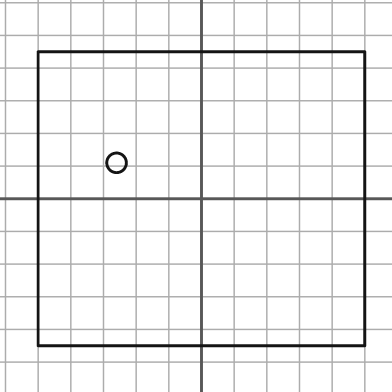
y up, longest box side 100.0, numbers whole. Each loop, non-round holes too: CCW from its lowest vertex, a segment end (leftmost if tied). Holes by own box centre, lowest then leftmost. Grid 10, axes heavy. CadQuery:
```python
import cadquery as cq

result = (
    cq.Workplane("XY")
    .moveTo(-50.0, -45.0)
    .lineTo(50.0, -45.0)
    .lineTo(50.0, 45.0)
    .lineTo(-50.0, 45.0)
    .close()
    .moveTo(-26.0, 11.0)
    .circle(3.0)
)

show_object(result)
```